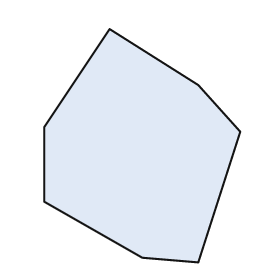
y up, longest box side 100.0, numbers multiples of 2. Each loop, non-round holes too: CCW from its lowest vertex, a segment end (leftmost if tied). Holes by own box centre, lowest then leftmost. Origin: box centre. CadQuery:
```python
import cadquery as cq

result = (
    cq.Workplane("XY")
    .moveTo(24.0, -50.0)
    .lineTo(42.0, 6.0)
    .lineTo(24.0, 26.0)
    .lineTo(-14.0, 50.0)
    .lineTo(-42.0, 8.0)
    .lineTo(-42.0, -24.0)
    .lineTo(0.0, -48.0)
    .close()
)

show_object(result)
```